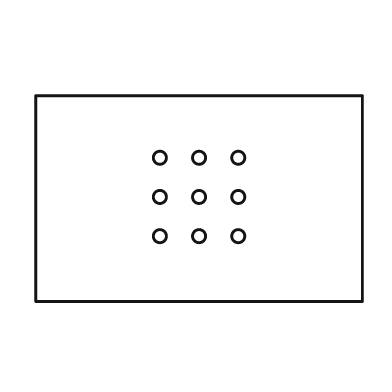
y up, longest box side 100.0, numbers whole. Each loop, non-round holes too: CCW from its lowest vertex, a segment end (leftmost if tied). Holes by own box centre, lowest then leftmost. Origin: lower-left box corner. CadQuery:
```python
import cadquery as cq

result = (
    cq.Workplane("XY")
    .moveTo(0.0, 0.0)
    .lineTo(100.0, 0.0)
    .lineTo(100.0, 63.0)
    .lineTo(0.0, 63.0)
    .close()
    .moveTo(38.0, 20.0)
    .circle(2.0)
    .moveTo(50.0, 20.0)
    .circle(2.0)
    .moveTo(62.0, 20.0)
    .circle(2.0)
    .moveTo(38.0, 32.0)
    .circle(2.0)
    .moveTo(50.0, 32.0)
    .circle(2.0)
    .moveTo(62.0, 32.0)
    .circle(2.0)
    .moveTo(38.0, 44.0)
    .circle(2.0)
    .moveTo(50.0, 44.0)
    .circle(2.0)
    .moveTo(62.0, 44.0)
    .circle(2.0)
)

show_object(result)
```